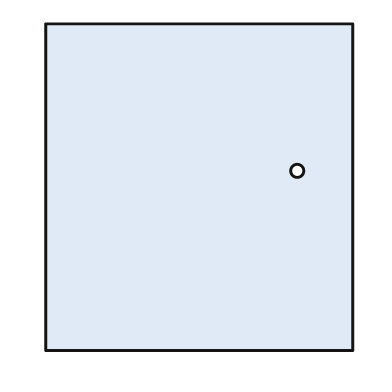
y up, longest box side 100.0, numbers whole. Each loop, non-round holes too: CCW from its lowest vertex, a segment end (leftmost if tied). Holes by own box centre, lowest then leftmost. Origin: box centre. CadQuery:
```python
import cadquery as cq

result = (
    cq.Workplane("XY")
    .moveTo(-47.0, -50.0)
    .lineTo(47.0, -50.0)
    .lineTo(47.0, 50.0)
    .lineTo(-47.0, 50.0)
    .close()
    .moveTo(30.0, 5.0)
    .circle(2.0)
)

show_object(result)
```